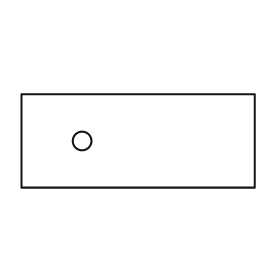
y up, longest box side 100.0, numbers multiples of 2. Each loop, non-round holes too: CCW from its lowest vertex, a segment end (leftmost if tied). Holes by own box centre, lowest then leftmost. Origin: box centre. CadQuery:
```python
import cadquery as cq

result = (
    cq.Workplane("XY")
    .moveTo(-50.0, -20.0)
    .lineTo(50.0, -20.0)
    .lineTo(50.0, 20.0)
    .lineTo(-50.0, 20.0)
    .close()
    .moveTo(-24.0, 0.0)
    .circle(4.0)
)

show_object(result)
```